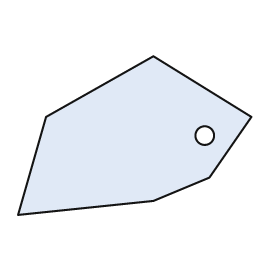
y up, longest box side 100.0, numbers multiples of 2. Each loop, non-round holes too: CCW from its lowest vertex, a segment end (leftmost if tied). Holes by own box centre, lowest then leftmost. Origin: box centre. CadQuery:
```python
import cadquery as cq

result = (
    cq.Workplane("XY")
    .moveTo(-50.0, -34.0)
    .lineTo(8.0, -28.0)
    .lineTo(32.0, -18.0)
    .lineTo(50.0, 8.0)
    .lineTo(8.0, 34.0)
    .lineTo(-38.0, 8.0)
    .close()
    .moveTo(30.0, 0.0)
    .circle(4.0)
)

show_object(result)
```